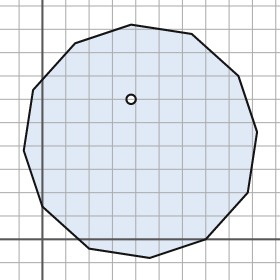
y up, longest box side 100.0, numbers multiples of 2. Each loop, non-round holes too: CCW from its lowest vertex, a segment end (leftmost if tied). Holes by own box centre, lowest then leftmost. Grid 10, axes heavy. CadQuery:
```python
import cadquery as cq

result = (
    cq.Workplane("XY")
    .moveTo(46.0, -8.0)
    .lineTo(70.0, 0.0)
    .lineTo(88.0, 20.0)
    .lineTo(92.0, 46.0)
    .lineTo(84.0, 70.0)
    .lineTo(64.0, 88.0)
    .lineTo(38.0, 92.0)
    .lineTo(14.0, 84.0)
    .lineTo(-4.0, 64.0)
    .lineTo(-8.0, 38.0)
    .lineTo(0.0, 14.0)
    .lineTo(20.0, -4.0)
    .close()
    .moveTo(38.0, 60.0)
    .circle(2.0)
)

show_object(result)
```